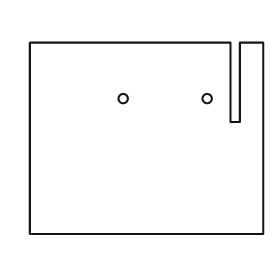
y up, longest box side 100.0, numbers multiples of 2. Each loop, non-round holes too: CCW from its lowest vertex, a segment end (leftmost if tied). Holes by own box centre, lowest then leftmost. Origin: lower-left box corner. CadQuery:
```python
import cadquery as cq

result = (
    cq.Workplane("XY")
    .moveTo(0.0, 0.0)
    .lineTo(100.0, 0.0)
    .lineTo(100.0, 82.0)
    .lineTo(90.0, 82.0)
    .lineTo(90.0, 48.0)
    .lineTo(86.0, 48.0)
    .lineTo(86.0, 82.0)
    .lineTo(0.0, 82.0)
    .close()
    .moveTo(40.0, 58.0)
    .circle(2.0)
    .moveTo(76.0, 58.0)
    .circle(2.0)
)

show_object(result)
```